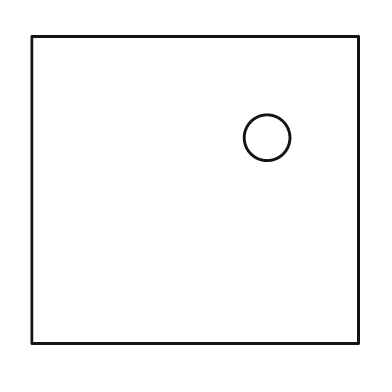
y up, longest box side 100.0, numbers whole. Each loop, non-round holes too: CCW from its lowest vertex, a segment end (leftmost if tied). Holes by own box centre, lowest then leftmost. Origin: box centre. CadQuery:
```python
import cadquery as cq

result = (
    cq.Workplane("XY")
    .moveTo(-50.0, -47.0)
    .lineTo(50.0, -47.0)
    .lineTo(50.0, 47.0)
    .lineTo(-50.0, 47.0)
    .close()
    .moveTo(22.0, 16.0)
    .circle(7.0)
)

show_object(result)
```